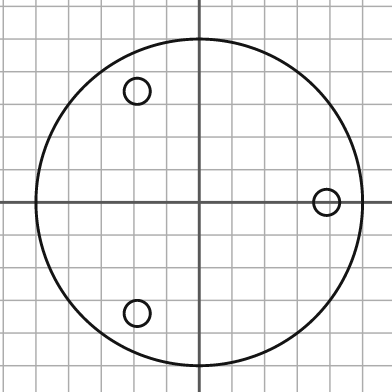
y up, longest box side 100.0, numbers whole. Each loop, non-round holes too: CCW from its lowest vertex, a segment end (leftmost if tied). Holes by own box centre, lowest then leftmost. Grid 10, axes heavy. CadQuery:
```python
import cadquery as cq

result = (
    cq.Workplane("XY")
    .moveTo(0.0, 0.0)
    .circle(50.0)
    .moveTo(-19.0, -34.0)
    .circle(4.0)
    .moveTo(39.0, 0.0)
    .circle(4.0)
    .moveTo(-19.0, 34.0)
    .circle(4.0)
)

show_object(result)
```